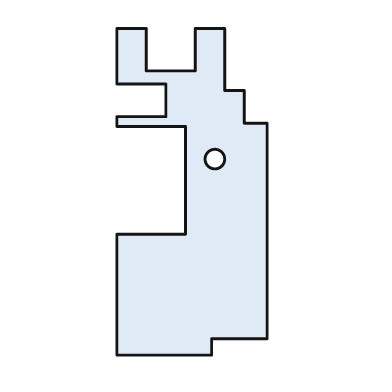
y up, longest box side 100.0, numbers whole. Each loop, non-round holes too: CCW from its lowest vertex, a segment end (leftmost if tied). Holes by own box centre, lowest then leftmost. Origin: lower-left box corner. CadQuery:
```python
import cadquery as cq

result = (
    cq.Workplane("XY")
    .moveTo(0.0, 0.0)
    .lineTo(29.0, 0.0)
    .lineTo(29.0, 5.0)
    .lineTo(46.0, 5.0)
    .lineTo(46.0, 71.0)
    .lineTo(39.0, 71.0)
    .lineTo(39.0, 81.0)
    .lineTo(33.0, 81.0)
    .lineTo(33.0, 100.0)
    .lineTo(24.0, 100.0)
    .lineTo(24.0, 87.0)
    .lineTo(9.0, 87.0)
    .lineTo(9.0, 100.0)
    .lineTo(0.0, 100.0)
    .lineTo(0.0, 83.0)
    .lineTo(15.0, 83.0)
    .lineTo(15.0, 73.0)
    .lineTo(0.0, 73.0)
    .lineTo(0.0, 70.0)
    .lineTo(21.0, 70.0)
    .lineTo(21.0, 37.0)
    .lineTo(0.0, 37.0)
    .close()
    .moveTo(30.0, 60.0)
    .circle(3.0)
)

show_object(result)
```